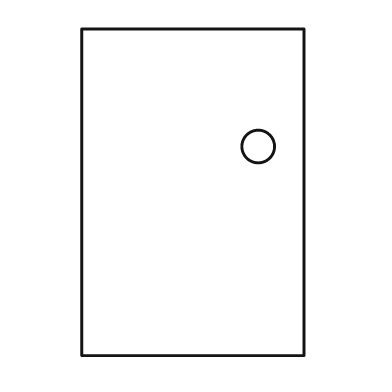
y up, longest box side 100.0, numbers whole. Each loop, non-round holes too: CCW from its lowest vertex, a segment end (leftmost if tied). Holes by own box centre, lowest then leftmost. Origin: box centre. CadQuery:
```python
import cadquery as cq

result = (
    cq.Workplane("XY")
    .moveTo(-34.0, -50.0)
    .lineTo(34.0, -50.0)
    .lineTo(34.0, 50.0)
    .lineTo(-34.0, 50.0)
    .close()
    .moveTo(20.0, 14.0)
    .circle(5.0)
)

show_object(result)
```